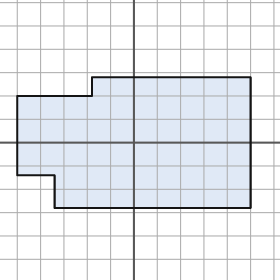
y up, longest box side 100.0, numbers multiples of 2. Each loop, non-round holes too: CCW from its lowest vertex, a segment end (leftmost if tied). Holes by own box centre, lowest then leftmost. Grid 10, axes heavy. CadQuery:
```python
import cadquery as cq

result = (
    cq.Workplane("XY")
    .moveTo(-34.0, -28.0)
    .lineTo(50.0, -28.0)
    .lineTo(50.0, 28.0)
    .lineTo(-18.0, 28.0)
    .lineTo(-18.0, 20.0)
    .lineTo(-50.0, 20.0)
    .lineTo(-50.0, -14.0)
    .lineTo(-34.0, -14.0)
    .close()
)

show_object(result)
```